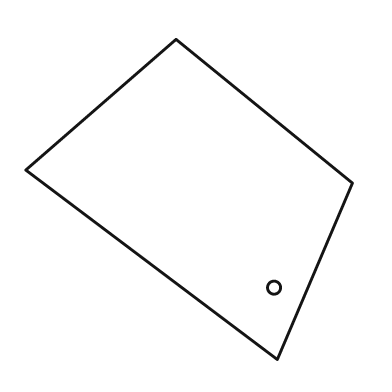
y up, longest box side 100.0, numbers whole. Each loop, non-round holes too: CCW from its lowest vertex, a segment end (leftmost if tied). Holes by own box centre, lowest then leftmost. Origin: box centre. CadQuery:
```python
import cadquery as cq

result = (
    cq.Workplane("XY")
    .moveTo(27.0, -49.0)
    .lineTo(50.0, 5.0)
    .lineTo(-4.0, 49.0)
    .lineTo(-50.0, 9.0)
    .close()
    .moveTo(26.0, -27.0)
    .circle(2.0)
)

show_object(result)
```